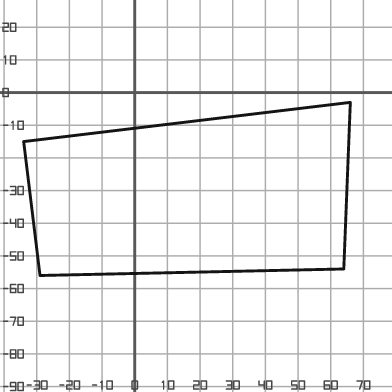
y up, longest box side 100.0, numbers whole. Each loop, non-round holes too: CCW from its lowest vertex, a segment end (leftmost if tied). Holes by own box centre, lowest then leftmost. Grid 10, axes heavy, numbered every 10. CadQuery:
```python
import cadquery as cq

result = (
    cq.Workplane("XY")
    .moveTo(-29.0, -56.0)
    .lineTo(64.0, -54.0)
    .lineTo(66.0, -3.0)
    .lineTo(-34.0, -15.0)
    .close()
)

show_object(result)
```